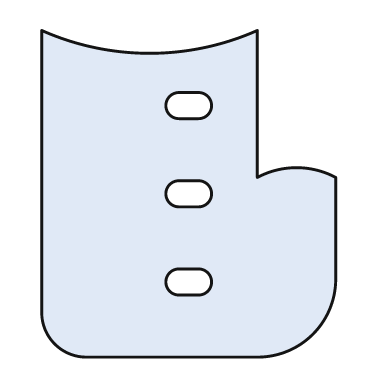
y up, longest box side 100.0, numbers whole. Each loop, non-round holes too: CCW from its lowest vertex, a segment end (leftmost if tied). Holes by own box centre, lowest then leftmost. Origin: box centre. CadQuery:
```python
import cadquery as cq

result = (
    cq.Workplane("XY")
    .moveTo(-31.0, -50.0)
    .lineTo(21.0, -50.0)
    .threePointArc((38.0, -43.0), (45.0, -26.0))
    .lineTo(45.0, 5.0)
    .threePointArc((33.0, 8.0), (21.0, 5.0))
    .lineTo(21.0, 50.0)
    .threePointArc((-12.0, 43.0), (-45.0, 50.0))
    .lineTo(-45.0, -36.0)
    .threePointArc((-41.0, -46.0), (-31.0, -50.0))
    .close()
    .moveTo(-3.0, -31.0)
    .lineTo(3.0, -31.0)
    .threePointArc((7.0, -27.0), (3.0, -23.0))
    .lineTo(-3.0, -23.0)
    .threePointArc((-7.0, -27.0), (-3.0, -31.0))
    .close()
    .moveTo(-3.0, -4.0)
    .lineTo(3.0, -4.0)
    .threePointArc((7.0, 0.0), (3.0, 4.0))
    .lineTo(-3.0, 4.0)
    .threePointArc((-7.0, 0.0), (-3.0, -4.0))
    .close()
    .moveTo(-3.0, 23.0)
    .lineTo(3.0, 23.0)
    .threePointArc((7.0, 27.0), (3.0, 31.0))
    .lineTo(-3.0, 31.0)
    .threePointArc((-7.0, 27.0), (-3.0, 23.0))
    .close()
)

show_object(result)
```